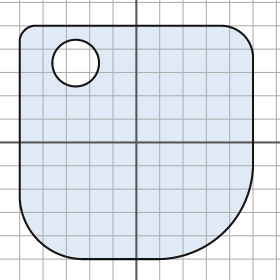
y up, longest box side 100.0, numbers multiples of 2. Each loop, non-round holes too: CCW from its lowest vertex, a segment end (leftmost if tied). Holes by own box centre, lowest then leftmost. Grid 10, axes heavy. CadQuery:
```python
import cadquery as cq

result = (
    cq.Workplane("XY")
    .moveTo(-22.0, -50.0)
    .lineTo(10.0, -50.0)
    .threePointArc((38.0, -38.0), (50.0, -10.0))
    .lineTo(50.0, 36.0)
    .threePointArc((46.0, 46.0), (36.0, 50.0))
    .lineTo(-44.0, 50.0)
    .threePointArc((-48.0, 48.0), (-50.0, 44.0))
    .lineTo(-50.0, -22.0)
    .threePointArc((-42.0, -42.0), (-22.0, -50.0))
    .close()
    .moveTo(-26.0, 34.0)
    .circle(10.0)
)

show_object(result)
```